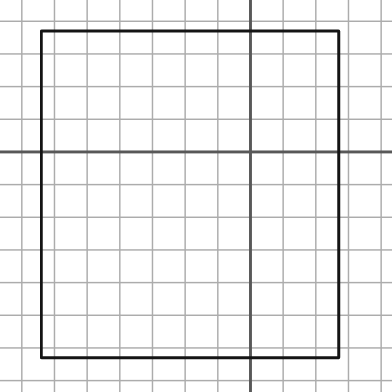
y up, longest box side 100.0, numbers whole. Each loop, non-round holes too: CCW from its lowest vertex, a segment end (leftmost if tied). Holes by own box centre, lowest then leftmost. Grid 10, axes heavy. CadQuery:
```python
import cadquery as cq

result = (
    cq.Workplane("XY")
    .moveTo(-64.0, -63.0)
    .lineTo(27.0, -63.0)
    .lineTo(27.0, 37.0)
    .lineTo(-64.0, 37.0)
    .close()
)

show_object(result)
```